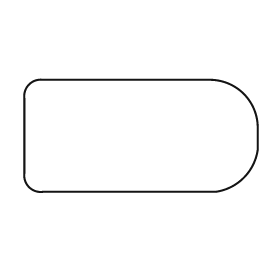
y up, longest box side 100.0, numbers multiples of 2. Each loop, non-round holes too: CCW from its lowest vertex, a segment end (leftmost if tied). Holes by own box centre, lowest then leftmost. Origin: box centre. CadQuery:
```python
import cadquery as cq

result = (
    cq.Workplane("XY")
    .moveTo(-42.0, -24.0)
    .lineTo(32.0, -24.0)
    .threePointArc((44.0, -18.0), (50.0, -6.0))
    .lineTo(50.0, 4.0)
    .threePointArc((44.0, 18.0), (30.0, 24.0))
    .lineTo(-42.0, 24.0)
    .threePointArc((-48.0, 22.0), (-50.0, 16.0))
    .lineTo(-50.0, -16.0)
    .threePointArc((-48.0, -22.0), (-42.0, -24.0))
    .close()
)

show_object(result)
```